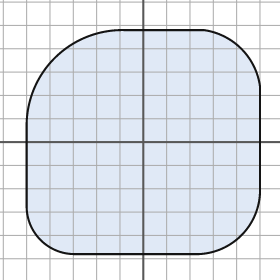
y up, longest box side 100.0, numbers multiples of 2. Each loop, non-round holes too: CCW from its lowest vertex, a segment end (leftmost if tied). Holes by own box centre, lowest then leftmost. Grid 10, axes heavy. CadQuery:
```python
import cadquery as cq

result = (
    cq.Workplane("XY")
    .moveTo(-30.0, -48.0)
    .lineTo(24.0, -48.0)
    .threePointArc((42.0, -40.0), (50.0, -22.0))
    .lineTo(50.0, 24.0)
    .threePointArc((42.0, 40.0), (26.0, 48.0))
    .lineTo(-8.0, 48.0)
    .threePointArc((-38.0, 36.0), (-50.0, 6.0))
    .lineTo(-50.0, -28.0)
    .threePointArc((-44.0, -42.0), (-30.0, -48.0))
    .close()
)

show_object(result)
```